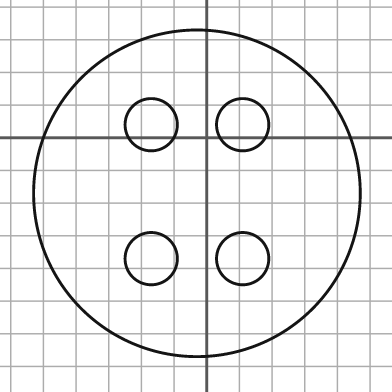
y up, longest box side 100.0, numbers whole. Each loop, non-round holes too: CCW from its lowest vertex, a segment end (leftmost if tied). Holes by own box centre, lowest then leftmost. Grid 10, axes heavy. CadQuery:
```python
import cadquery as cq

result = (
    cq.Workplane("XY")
    .moveTo(-3.0, -17.0)
    .circle(50.0)
    .moveTo(-17.0, -37.0)
    .circle(8.0)
    .moveTo(11.0, -37.0)
    .circle(8.0)
    .moveTo(-17.0, 4.0)
    .circle(8.0)
    .moveTo(11.0, 4.0)
    .circle(8.0)
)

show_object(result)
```